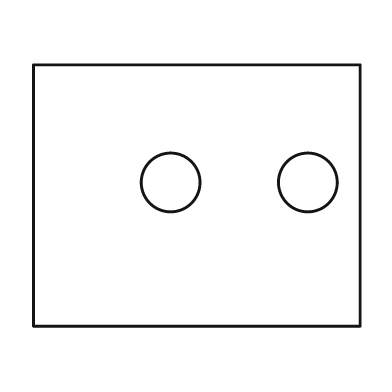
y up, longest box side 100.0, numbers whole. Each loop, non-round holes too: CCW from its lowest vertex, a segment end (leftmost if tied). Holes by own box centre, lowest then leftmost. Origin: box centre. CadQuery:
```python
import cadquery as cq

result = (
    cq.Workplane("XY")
    .moveTo(-50.0, -40.0)
    .lineTo(50.0, -40.0)
    .lineTo(50.0, 40.0)
    .lineTo(-50.0, 40.0)
    .close()
    .moveTo(-8.0, 4.0)
    .circle(9.0)
    .moveTo(34.0, 4.0)
    .circle(9.0)
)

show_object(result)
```